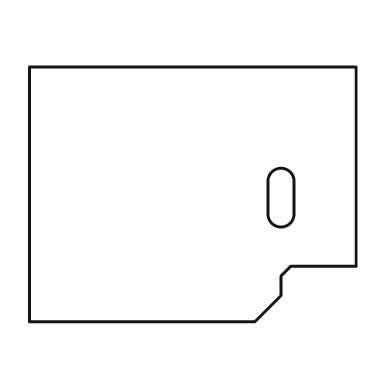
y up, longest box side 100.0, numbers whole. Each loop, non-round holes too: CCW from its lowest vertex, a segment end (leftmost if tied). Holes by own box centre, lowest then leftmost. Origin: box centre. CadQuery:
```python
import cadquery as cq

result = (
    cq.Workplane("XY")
    .moveTo(-50.0, -39.0)
    .lineTo(19.0, -39.0)
    .lineTo(27.0, -31.0)
    .lineTo(27.0, -25.0)
    .lineTo(30.0, -22.0)
    .lineTo(50.0, -22.0)
    .lineTo(50.0, 39.0)
    .lineTo(-50.0, 39.0)
    .close()
    .moveTo(23.0, -6.0)
    .threePointArc((27.0, -10.0), (31.0, -6.0))
    .lineTo(31.0, 4.0)
    .threePointArc((27.0, 8.0), (23.0, 4.0))
    .close()
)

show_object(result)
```